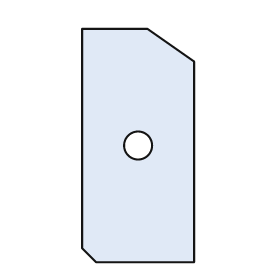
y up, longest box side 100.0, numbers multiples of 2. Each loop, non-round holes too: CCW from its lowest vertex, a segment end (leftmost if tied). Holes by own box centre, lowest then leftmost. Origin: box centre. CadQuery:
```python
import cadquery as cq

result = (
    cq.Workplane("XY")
    .moveTo(-18.0, -50.0)
    .lineTo(24.0, -50.0)
    .lineTo(24.0, 36.0)
    .lineTo(4.0, 50.0)
    .lineTo(-24.0, 50.0)
    .lineTo(-24.0, -44.0)
    .close()
    .moveTo(0.0, 0.0)
    .circle(6.0)
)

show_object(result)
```